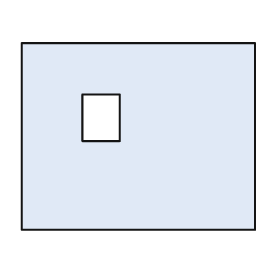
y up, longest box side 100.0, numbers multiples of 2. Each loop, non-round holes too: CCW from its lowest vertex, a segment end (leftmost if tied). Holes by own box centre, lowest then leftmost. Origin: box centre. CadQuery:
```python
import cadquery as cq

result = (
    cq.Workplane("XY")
    .moveTo(-50.0, -40.0)
    .lineTo(50.0, -40.0)
    .lineTo(50.0, 40.0)
    .lineTo(-50.0, 40.0)
    .close()
    .moveTo(-24.0, -2.0)
    .lineTo(-8.0, -2.0)
    .lineTo(-8.0, 18.0)
    .lineTo(-24.0, 18.0)
    .close()
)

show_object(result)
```